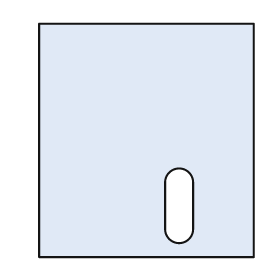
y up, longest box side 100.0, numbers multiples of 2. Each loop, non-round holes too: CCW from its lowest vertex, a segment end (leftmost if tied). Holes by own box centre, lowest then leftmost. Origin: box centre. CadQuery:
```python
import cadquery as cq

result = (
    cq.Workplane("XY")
    .moveTo(-46.0, -50.0)
    .lineTo(46.0, -50.0)
    .lineTo(46.0, 50.0)
    .lineTo(-46.0, 50.0)
    .close()
    .moveTo(8.0, -38.0)
    .threePointArc((14.0, -44.0), (20.0, -38.0))
    .lineTo(20.0, -18.0)
    .threePointArc((14.0, -12.0), (8.0, -18.0))
    .close()
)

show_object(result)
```